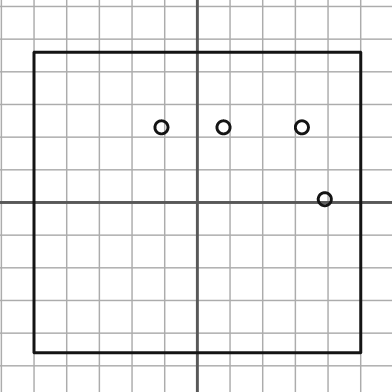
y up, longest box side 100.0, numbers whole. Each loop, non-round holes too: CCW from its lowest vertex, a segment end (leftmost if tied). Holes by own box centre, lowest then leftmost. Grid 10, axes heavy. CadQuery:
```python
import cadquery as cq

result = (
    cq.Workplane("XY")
    .moveTo(-50.0, -46.0)
    .lineTo(50.0, -46.0)
    .lineTo(50.0, 46.0)
    .lineTo(-50.0, 46.0)
    .close()
    .moveTo(39.0, 1.0)
    .circle(2.0)
    .moveTo(-11.0, 23.0)
    .circle(2.0)
    .moveTo(8.0, 23.0)
    .circle(2.0)
    .moveTo(32.0, 23.0)
    .circle(2.0)
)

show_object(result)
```